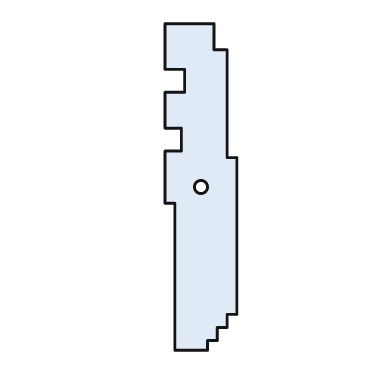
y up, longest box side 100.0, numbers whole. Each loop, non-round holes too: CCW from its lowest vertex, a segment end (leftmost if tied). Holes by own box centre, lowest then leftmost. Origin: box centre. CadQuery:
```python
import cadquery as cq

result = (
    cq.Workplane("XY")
    .moveTo(-8.0, -50.0)
    .lineTo(2.0, -50.0)
    .lineTo(2.0, -47.0)
    .lineTo(5.0, -47.0)
    .lineTo(5.0, -43.0)
    .lineTo(8.0, -43.0)
    .lineTo(8.0, -39.0)
    .lineTo(11.0, -39.0)
    .lineTo(11.0, 9.0)
    .lineTo(8.0, 9.0)
    .lineTo(8.0, 42.0)
    .lineTo(4.0, 42.0)
    .lineTo(4.0, 50.0)
    .lineTo(-11.0, 50.0)
    .lineTo(-11.0, 36.0)
    .lineTo(-5.0, 36.0)
    .lineTo(-5.0, 29.0)
    .lineTo(-11.0, 29.0)
    .lineTo(-11.0, 18.0)
    .lineTo(-6.0, 18.0)
    .lineTo(-6.0, 11.0)
    .lineTo(-11.0, 11.0)
    .lineTo(-11.0, -5.0)
    .lineTo(-8.0, -5.0)
    .close()
    .moveTo(0.0, 0.0)
    .circle(2.0)
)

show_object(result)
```